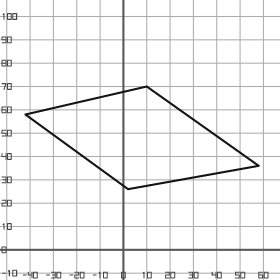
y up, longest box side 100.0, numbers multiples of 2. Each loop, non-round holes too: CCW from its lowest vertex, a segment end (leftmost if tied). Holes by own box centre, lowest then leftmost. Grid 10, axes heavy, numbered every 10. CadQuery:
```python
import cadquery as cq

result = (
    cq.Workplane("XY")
    .moveTo(2.0, 26.0)
    .lineTo(58.0, 36.0)
    .lineTo(10.0, 70.0)
    .lineTo(-42.0, 58.0)
    .close()
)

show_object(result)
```